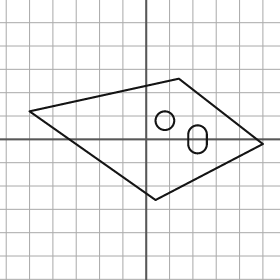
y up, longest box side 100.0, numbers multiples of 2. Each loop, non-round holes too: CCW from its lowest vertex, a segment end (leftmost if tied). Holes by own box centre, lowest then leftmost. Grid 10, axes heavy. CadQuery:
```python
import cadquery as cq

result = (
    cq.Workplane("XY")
    .moveTo(4.0, -26.0)
    .lineTo(50.0, -2.0)
    .lineTo(14.0, 26.0)
    .lineTo(-50.0, 12.0)
    .close()
    .moveTo(18.0, -2.0)
    .threePointArc((22.0, -6.0), (26.0, -2.0))
    .lineTo(26.0, 2.0)
    .threePointArc((22.0, 6.0), (18.0, 2.0))
    .close()
    .moveTo(8.0, 8.0)
    .circle(4.0)
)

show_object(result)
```